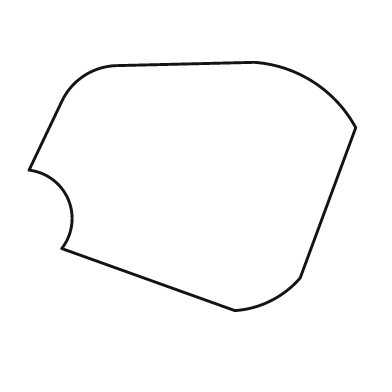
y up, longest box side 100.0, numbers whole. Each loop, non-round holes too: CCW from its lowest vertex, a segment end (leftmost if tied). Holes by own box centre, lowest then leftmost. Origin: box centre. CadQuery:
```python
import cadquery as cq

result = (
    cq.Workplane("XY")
    .moveTo(13.0, -38.0)
    .threePointArc((24.0, -35.0), (33.0, -28.0))
    .lineTo(50.0, 18.0)
    .threePointArc((37.0, 32.0), (19.0, 38.0))
    .lineTo(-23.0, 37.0)
    .threePointArc((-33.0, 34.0), (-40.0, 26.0))
    .lineTo(-50.0, 5.0)
    .threePointArc((-38.0, -4.0), (-40.0, -19.0))
    .close()
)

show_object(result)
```